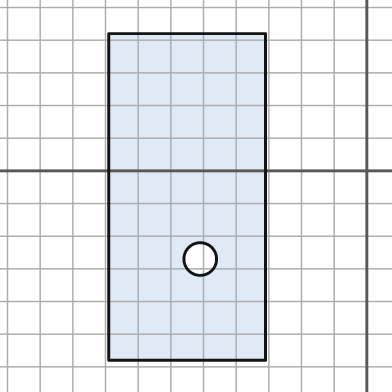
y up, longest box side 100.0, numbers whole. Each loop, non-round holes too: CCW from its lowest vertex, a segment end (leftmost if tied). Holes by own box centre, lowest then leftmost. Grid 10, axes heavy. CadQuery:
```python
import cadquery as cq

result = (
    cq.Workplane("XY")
    .moveTo(-79.0, -58.0)
    .lineTo(-31.0, -58.0)
    .lineTo(-31.0, 42.0)
    .lineTo(-79.0, 42.0)
    .close()
    .moveTo(-51.0, -27.0)
    .circle(5.0)
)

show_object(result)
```